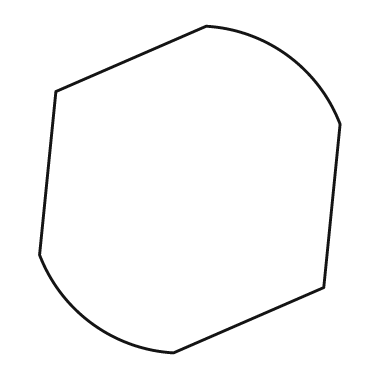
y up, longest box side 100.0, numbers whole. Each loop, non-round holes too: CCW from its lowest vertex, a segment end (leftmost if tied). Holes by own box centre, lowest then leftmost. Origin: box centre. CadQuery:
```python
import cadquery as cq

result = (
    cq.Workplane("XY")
    .moveTo(-5.0, -50.0)
    .lineTo(41.0, -30.0)
    .lineTo(46.0, 20.0)
    .threePointArc((30.0, 41.0), (5.0, 50.0))
    .lineTo(-41.0, 30.0)
    .lineTo(-46.0, -20.0)
    .threePointArc((-30.0, -41.0), (-5.0, -50.0))
    .close()
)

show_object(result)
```